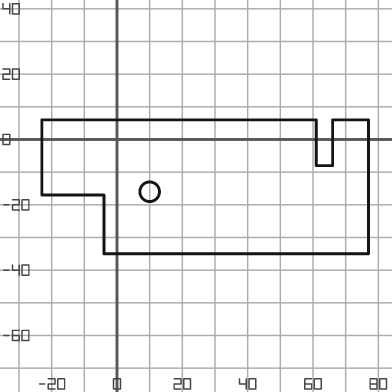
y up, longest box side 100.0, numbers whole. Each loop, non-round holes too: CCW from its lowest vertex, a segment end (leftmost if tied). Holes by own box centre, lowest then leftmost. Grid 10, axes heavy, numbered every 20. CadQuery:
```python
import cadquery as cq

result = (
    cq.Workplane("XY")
    .moveTo(-4.0, -35.0)
    .lineTo(77.0, -35.0)
    .lineTo(77.0, 6.0)
    .lineTo(66.0, 6.0)
    .lineTo(66.0, -8.0)
    .lineTo(61.0, -8.0)
    .lineTo(61.0, 6.0)
    .lineTo(-23.0, 6.0)
    .lineTo(-23.0, -17.0)
    .lineTo(-4.0, -17.0)
    .close()
    .moveTo(10.0, -16.0)
    .circle(3.0)
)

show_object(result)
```